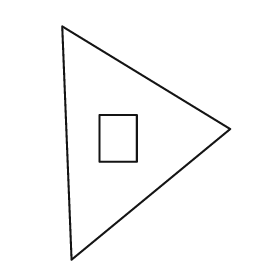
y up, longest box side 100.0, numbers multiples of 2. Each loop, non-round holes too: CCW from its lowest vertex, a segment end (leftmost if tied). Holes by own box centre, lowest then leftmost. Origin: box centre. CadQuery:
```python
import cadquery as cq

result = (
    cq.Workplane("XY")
    .moveTo(-32.0, -50.0)
    .lineTo(36.0, 6.0)
    .lineTo(-36.0, 50.0)
    .close()
    .moveTo(-20.0, -8.0)
    .lineTo(-4.0, -8.0)
    .lineTo(-4.0, 12.0)
    .lineTo(-20.0, 12.0)
    .close()
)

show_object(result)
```